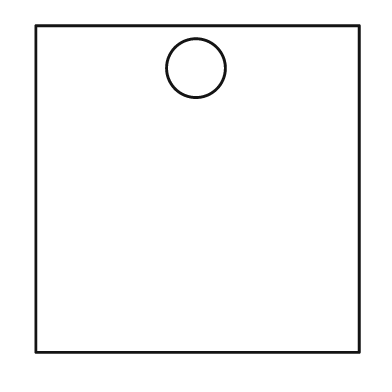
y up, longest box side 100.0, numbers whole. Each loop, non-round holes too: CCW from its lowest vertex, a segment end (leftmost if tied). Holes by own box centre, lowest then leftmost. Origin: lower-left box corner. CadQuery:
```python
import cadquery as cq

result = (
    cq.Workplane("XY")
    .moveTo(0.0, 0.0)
    .lineTo(99.0, 0.0)
    .lineTo(99.0, 100.0)
    .lineTo(0.0, 100.0)
    .close()
    .moveTo(49.0, 87.0)
    .circle(9.0)
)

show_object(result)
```